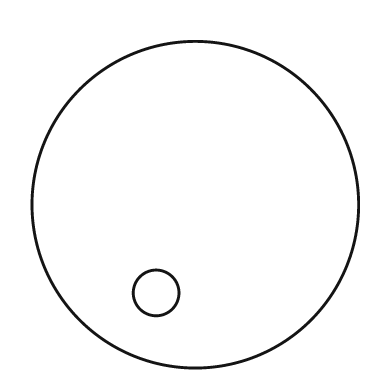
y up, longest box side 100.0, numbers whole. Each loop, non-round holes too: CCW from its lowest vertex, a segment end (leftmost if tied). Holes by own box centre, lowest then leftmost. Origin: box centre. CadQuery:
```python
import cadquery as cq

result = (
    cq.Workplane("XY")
    .moveTo(0.0, 0.0)
    .circle(50.0)
    .moveTo(-12.0, -27.0)
    .circle(7.0)
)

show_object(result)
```